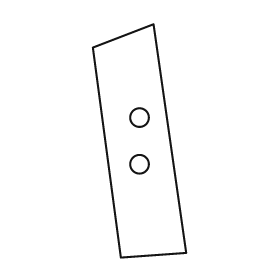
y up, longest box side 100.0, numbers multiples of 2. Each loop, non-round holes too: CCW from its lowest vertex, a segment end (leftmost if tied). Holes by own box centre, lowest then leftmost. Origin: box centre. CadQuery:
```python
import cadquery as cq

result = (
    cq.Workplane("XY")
    .moveTo(-8.0, -50.0)
    .lineTo(20.0, -48.0)
    .lineTo(6.0, 50.0)
    .lineTo(-20.0, 40.0)
    .close()
    .moveTo(0.0, -10.0)
    .circle(4.0)
    .moveTo(0.0, 10.0)
    .circle(4.0)
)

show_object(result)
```